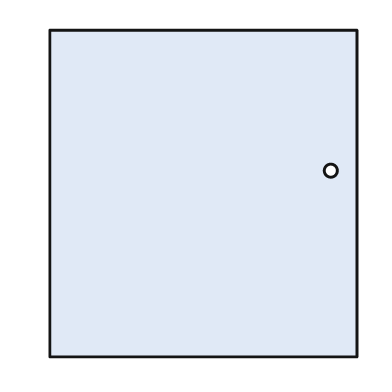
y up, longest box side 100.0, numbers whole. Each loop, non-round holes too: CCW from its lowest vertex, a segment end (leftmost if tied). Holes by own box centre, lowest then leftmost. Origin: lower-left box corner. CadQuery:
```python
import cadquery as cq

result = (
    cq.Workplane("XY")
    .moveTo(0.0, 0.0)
    .lineTo(94.0, 0.0)
    .lineTo(94.0, 100.0)
    .lineTo(0.0, 100.0)
    .close()
    .moveTo(86.0, 57.0)
    .circle(2.0)
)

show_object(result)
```